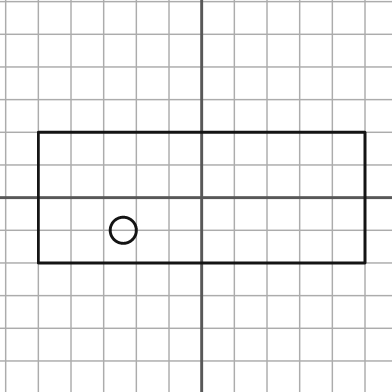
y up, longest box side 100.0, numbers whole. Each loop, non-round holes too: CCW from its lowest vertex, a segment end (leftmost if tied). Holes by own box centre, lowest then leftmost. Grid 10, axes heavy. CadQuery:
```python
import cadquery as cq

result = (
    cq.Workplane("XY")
    .moveTo(-50.0, -20.0)
    .lineTo(50.0, -20.0)
    .lineTo(50.0, 20.0)
    .lineTo(-50.0, 20.0)
    .close()
    .moveTo(-24.0, -10.0)
    .circle(4.0)
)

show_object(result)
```